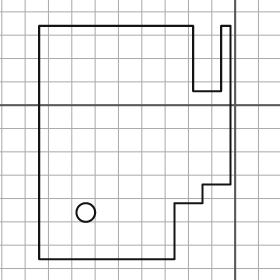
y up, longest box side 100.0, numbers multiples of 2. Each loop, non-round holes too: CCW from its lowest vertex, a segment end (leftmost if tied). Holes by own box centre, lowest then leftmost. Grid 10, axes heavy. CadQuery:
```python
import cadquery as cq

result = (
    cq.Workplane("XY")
    .moveTo(-84.0, -66.0)
    .lineTo(-26.0, -66.0)
    .lineTo(-26.0, -42.0)
    .lineTo(-14.0, -42.0)
    .lineTo(-14.0, -34.0)
    .lineTo(-2.0, -34.0)
    .lineTo(-2.0, 34.0)
    .lineTo(-6.0, 34.0)
    .lineTo(-6.0, 6.0)
    .lineTo(-18.0, 6.0)
    .lineTo(-18.0, 34.0)
    .lineTo(-84.0, 34.0)
    .close()
    .moveTo(-64.0, -46.0)
    .circle(4.0)
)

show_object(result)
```